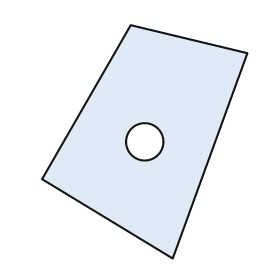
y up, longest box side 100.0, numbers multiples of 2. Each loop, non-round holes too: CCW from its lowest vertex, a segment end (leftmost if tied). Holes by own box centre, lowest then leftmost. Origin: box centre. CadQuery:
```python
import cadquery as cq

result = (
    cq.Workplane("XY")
    .moveTo(12.0, -50.0)
    .lineTo(44.0, 38.0)
    .lineTo(-6.0, 50.0)
    .lineTo(-44.0, -16.0)
    .close()
    .moveTo(0.0, 0.0)
    .circle(8.0)
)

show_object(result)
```